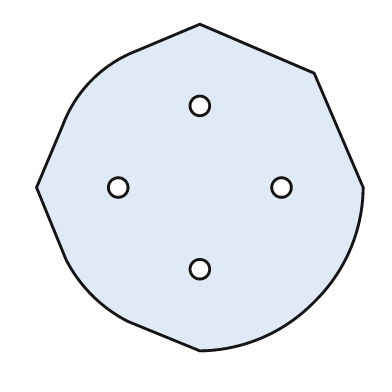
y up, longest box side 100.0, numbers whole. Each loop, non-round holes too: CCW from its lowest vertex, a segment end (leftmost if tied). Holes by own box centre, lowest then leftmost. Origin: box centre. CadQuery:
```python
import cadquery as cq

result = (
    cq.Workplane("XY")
    .moveTo(0.0, -50.0)
    .threePointArc((19.0, -46.0), (35.0, -35.0))
    .threePointArc((46.0, -19.0), (50.0, 0.0))
    .lineTo(35.0, 35.0)
    .lineTo(0.0, 50.0)
    .lineTo(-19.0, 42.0)
    .threePointArc((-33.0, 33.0), (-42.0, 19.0))
    .lineTo(-50.0, 0.0)
    .lineTo(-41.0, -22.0)
    .threePointArc((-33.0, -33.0), (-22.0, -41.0))
    .close()
    .moveTo(0.0, -25.0)
    .circle(3.0)
    .moveTo(-25.0, 0.0)
    .circle(3.0)
    .moveTo(25.0, 0.0)
    .circle(3.0)
    .moveTo(0.0, 25.0)
    .circle(3.0)
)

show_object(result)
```